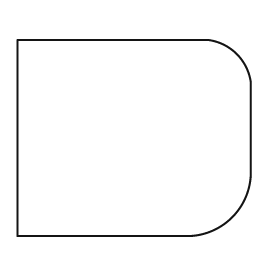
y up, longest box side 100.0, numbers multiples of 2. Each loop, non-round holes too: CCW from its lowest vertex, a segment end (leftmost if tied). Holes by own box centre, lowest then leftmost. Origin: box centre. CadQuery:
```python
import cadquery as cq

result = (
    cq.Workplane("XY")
    .moveTo(-50.0, -42.0)
    .lineTo(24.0, -42.0)
    .threePointArc((42.0, -34.0), (50.0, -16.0))
    .lineTo(50.0, 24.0)
    .threePointArc((44.0, 36.0), (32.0, 42.0))
    .lineTo(-50.0, 42.0)
    .close()
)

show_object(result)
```